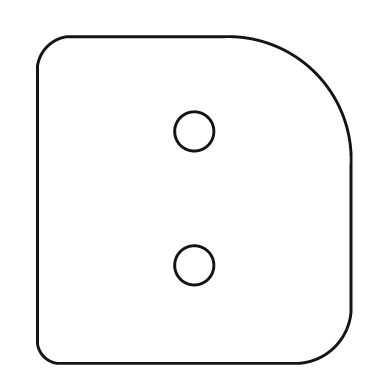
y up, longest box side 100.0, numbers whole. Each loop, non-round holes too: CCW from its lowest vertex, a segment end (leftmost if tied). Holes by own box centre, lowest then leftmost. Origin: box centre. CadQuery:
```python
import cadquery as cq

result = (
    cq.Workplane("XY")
    .moveTo(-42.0, -50.0)
    .lineTo(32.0, -50.0)
    .threePointArc((43.0, -45.0), (48.0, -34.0))
    .lineTo(48.0, 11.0)
    .threePointArc((37.0, 39.0), (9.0, 50.0))
    .lineTo(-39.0, 50.0)
    .threePointArc((-45.0, 47.0), (-48.0, 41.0))
    .lineTo(-48.0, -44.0)
    .threePointArc((-46.0, -48.0), (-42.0, -50.0))
    .close()
    .moveTo(0.0, -20.0)
    .circle(6.0)
    .moveTo(0.0, 21.0)
    .circle(6.0)
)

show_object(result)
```